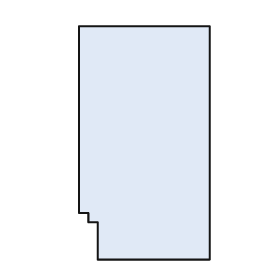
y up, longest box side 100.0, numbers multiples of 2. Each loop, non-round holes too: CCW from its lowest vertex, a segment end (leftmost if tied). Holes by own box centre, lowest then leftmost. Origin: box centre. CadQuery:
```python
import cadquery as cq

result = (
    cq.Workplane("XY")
    .moveTo(-20.0, -50.0)
    .lineTo(28.0, -50.0)
    .lineTo(28.0, 50.0)
    .lineTo(-28.0, 50.0)
    .lineTo(-28.0, -30.0)
    .lineTo(-24.0, -30.0)
    .lineTo(-24.0, -34.0)
    .lineTo(-20.0, -34.0)
    .close()
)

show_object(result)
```